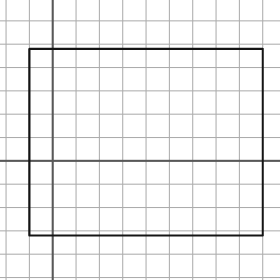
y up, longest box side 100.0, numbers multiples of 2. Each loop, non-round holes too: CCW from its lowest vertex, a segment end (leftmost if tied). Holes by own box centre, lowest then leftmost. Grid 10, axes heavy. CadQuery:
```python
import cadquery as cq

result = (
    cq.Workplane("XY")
    .moveTo(-10.0, -32.0)
    .lineTo(90.0, -32.0)
    .lineTo(90.0, 48.0)
    .lineTo(-10.0, 48.0)
    .close()
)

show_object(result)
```